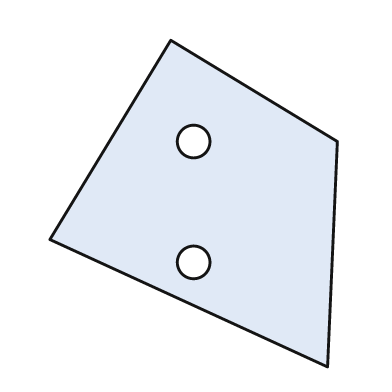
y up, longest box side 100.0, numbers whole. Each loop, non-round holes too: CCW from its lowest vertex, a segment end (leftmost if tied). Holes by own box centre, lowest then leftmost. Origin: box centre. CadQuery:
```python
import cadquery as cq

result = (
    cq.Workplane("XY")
    .moveTo(41.0, -50.0)
    .lineTo(44.0, 19.0)
    .lineTo(-7.0, 50.0)
    .lineTo(-44.0, -11.0)
    .close()
    .moveTo(0.0, -18.0)
    .circle(5.0)
    .moveTo(0.0, 19.0)
    .circle(5.0)
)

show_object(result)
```